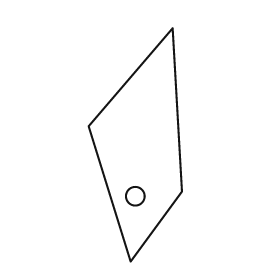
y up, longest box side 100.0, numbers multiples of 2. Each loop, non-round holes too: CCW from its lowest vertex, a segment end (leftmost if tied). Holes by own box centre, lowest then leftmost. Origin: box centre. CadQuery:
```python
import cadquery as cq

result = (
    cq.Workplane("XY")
    .moveTo(-2.0, -50.0)
    .lineTo(20.0, -20.0)
    .lineTo(16.0, 50.0)
    .lineTo(-20.0, 8.0)
    .close()
    .moveTo(0.0, -22.0)
    .circle(4.0)
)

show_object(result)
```